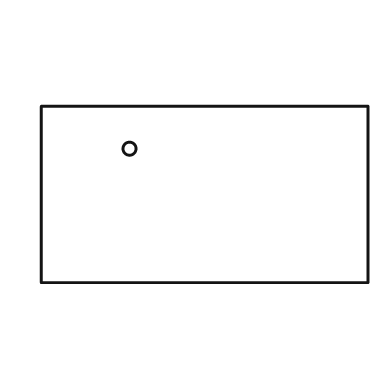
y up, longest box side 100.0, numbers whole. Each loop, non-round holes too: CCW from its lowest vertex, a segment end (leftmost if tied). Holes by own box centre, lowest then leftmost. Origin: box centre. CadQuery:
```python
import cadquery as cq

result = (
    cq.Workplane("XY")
    .moveTo(-50.0, -27.0)
    .lineTo(50.0, -27.0)
    .lineTo(50.0, 27.0)
    .lineTo(-50.0, 27.0)
    .close()
    .moveTo(-23.0, 14.0)
    .circle(2.0)
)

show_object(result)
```